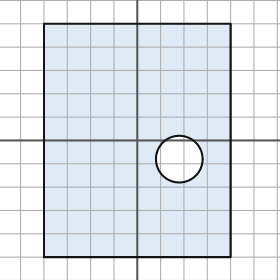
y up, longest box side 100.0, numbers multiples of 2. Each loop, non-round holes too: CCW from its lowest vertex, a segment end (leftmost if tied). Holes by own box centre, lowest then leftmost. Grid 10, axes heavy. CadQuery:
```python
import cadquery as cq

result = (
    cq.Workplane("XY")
    .moveTo(-40.0, -50.0)
    .lineTo(40.0, -50.0)
    .lineTo(40.0, 50.0)
    .lineTo(-40.0, 50.0)
    .close()
    .moveTo(18.0, -8.0)
    .circle(10.0)
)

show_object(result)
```